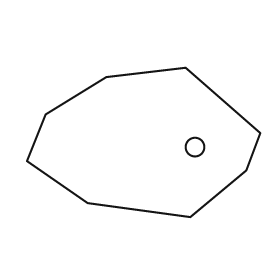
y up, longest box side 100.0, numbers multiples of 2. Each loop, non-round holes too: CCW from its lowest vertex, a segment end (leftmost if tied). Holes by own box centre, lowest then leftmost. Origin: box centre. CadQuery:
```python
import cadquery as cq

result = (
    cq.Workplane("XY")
    .moveTo(20.0, -32.0)
    .lineTo(44.0, -12.0)
    .lineTo(50.0, 4.0)
    .lineTo(18.0, 32.0)
    .lineTo(-16.0, 28.0)
    .lineTo(-42.0, 12.0)
    .lineTo(-50.0, -8.0)
    .lineTo(-24.0, -26.0)
    .close()
    .moveTo(22.0, -2.0)
    .circle(4.0)
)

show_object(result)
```